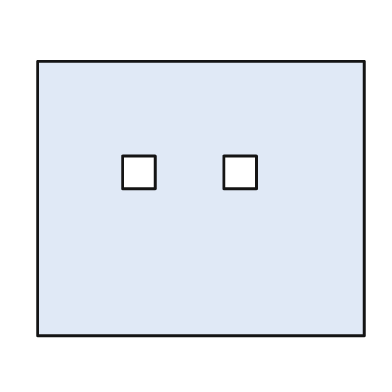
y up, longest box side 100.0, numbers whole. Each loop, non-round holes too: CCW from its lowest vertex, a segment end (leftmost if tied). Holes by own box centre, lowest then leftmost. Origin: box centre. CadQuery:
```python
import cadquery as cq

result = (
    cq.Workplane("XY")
    .moveTo(-50.0, -42.0)
    .lineTo(50.0, -42.0)
    .lineTo(50.0, 42.0)
    .lineTo(-50.0, 42.0)
    .close()
    .moveTo(-24.0, 3.0)
    .lineTo(-14.0, 3.0)
    .lineTo(-14.0, 13.0)
    .lineTo(-24.0, 13.0)
    .close()
    .moveTo(7.0, 3.0)
    .lineTo(17.0, 3.0)
    .lineTo(17.0, 13.0)
    .lineTo(7.0, 13.0)
    .close()
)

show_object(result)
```